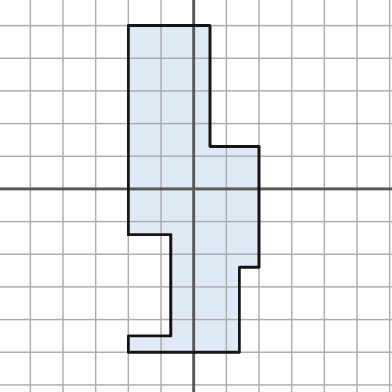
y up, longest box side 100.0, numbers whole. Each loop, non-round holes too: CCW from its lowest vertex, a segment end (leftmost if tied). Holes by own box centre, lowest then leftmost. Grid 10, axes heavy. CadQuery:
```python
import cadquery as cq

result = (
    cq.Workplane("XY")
    .moveTo(-20.0, -50.0)
    .lineTo(14.0, -50.0)
    .lineTo(14.0, -24.0)
    .lineTo(20.0, -24.0)
    .lineTo(20.0, 13.0)
    .lineTo(5.0, 13.0)
    .lineTo(5.0, 50.0)
    .lineTo(-20.0, 50.0)
    .lineTo(-20.0, -14.0)
    .lineTo(-7.0, -14.0)
    .lineTo(-7.0, -45.0)
    .lineTo(-20.0, -45.0)
    .close()
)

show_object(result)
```